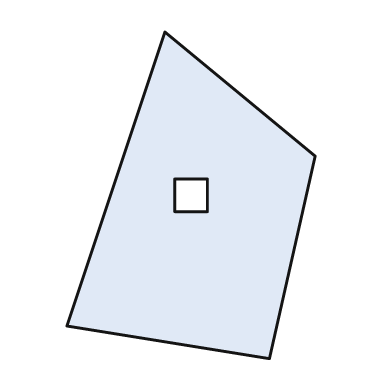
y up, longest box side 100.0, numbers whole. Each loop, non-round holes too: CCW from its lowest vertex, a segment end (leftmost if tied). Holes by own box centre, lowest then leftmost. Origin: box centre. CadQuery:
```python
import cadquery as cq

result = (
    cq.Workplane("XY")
    .moveTo(24.0, -50.0)
    .lineTo(38.0, 12.0)
    .lineTo(-8.0, 50.0)
    .lineTo(-38.0, -40.0)
    .close()
    .moveTo(-5.0, -5.0)
    .lineTo(5.0, -5.0)
    .lineTo(5.0, 5.0)
    .lineTo(-5.0, 5.0)
    .close()
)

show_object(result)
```